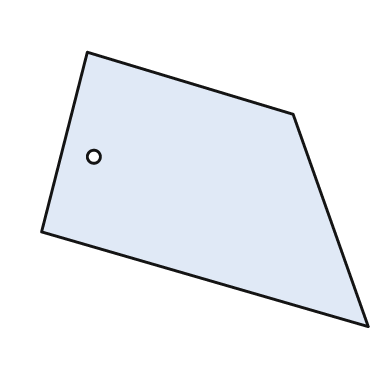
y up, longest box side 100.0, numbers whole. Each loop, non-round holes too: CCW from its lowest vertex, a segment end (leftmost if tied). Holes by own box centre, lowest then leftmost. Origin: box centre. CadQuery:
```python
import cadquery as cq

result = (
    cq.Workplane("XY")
    .moveTo(50.0, -42.0)
    .lineTo(27.0, 23.0)
    .lineTo(-36.0, 42.0)
    .lineTo(-50.0, -13.0)
    .close()
    .moveTo(-34.0, 10.0)
    .circle(2.0)
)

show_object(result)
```